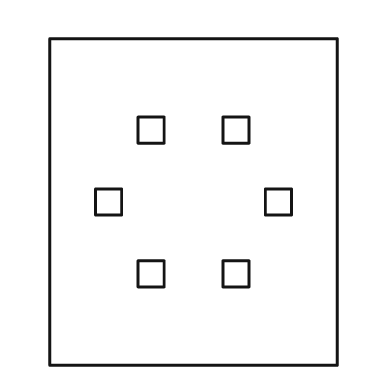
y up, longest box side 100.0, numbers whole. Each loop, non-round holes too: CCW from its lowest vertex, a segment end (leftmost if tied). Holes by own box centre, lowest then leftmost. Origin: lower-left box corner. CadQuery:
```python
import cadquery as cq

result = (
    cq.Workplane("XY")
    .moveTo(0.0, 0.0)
    .lineTo(88.0, 0.0)
    .lineTo(88.0, 100.0)
    .lineTo(0.0, 100.0)
    .close()
    .moveTo(27.0, 24.0)
    .lineTo(35.0, 24.0)
    .lineTo(35.0, 32.0)
    .lineTo(27.0, 32.0)
    .close()
    .moveTo(53.0, 24.0)
    .lineTo(61.0, 24.0)
    .lineTo(61.0, 32.0)
    .lineTo(53.0, 32.0)
    .close()
    .moveTo(14.0, 46.0)
    .lineTo(22.0, 46.0)
    .lineTo(22.0, 54.0)
    .lineTo(14.0, 54.0)
    .close()
    .moveTo(66.0, 46.0)
    .lineTo(74.0, 46.0)
    .lineTo(74.0, 54.0)
    .lineTo(66.0, 54.0)
    .close()
    .moveTo(27.0, 68.0)
    .lineTo(35.0, 68.0)
    .lineTo(35.0, 76.0)
    .lineTo(27.0, 76.0)
    .close()
    .moveTo(53.0, 68.0)
    .lineTo(61.0, 68.0)
    .lineTo(61.0, 76.0)
    .lineTo(53.0, 76.0)
    .close()
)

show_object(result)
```